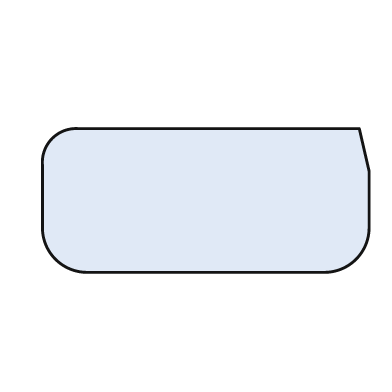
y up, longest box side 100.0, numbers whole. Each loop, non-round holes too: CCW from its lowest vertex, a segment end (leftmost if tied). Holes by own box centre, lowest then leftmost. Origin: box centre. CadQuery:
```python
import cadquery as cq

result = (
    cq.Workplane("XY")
    .moveTo(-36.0, -22.0)
    .lineTo(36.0, -22.0)
    .threePointArc((46.0, -18.0), (50.0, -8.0))
    .lineTo(50.0, 9.0)
    .lineTo(47.0, 22.0)
    .lineTo(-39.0, 22.0)
    .threePointArc((-47.0, 19.0), (-50.0, 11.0))
    .lineTo(-50.0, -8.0)
    .threePointArc((-46.0, -18.0), (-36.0, -22.0))
    .close()
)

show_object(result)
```